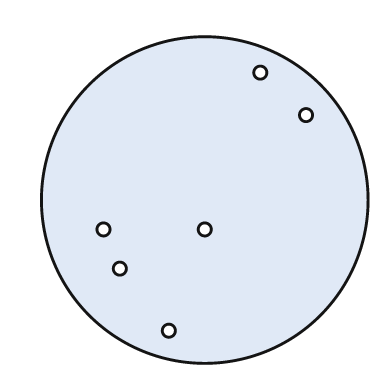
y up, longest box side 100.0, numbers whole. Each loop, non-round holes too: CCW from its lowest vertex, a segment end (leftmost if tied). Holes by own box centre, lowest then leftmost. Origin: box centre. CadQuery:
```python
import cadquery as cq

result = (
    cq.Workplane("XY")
    .moveTo(0.0, 0.0)
    .circle(50.0)
    .moveTo(-11.0, -40.0)
    .circle(2.0)
    .moveTo(-26.0, -21.0)
    .circle(2.0)
    .moveTo(-31.0, -9.0)
    .circle(2.0)
    .moveTo(0.0, -9.0)
    .circle(2.0)
    .moveTo(31.0, 26.0)
    .circle(2.0)
    .moveTo(17.0, 39.0)
    .circle(2.0)
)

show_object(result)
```